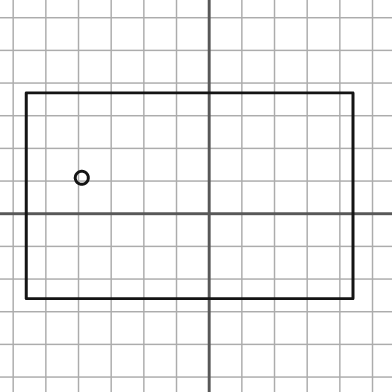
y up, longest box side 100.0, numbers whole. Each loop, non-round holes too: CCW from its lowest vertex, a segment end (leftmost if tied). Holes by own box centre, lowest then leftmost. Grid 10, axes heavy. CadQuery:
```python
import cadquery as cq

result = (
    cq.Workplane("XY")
    .moveTo(-56.0, -26.0)
    .lineTo(44.0, -26.0)
    .lineTo(44.0, 37.0)
    .lineTo(-56.0, 37.0)
    .close()
    .moveTo(-39.0, 11.0)
    .circle(2.0)
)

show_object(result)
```